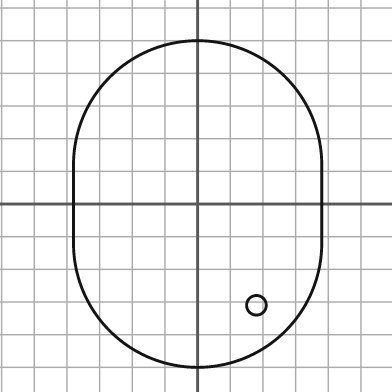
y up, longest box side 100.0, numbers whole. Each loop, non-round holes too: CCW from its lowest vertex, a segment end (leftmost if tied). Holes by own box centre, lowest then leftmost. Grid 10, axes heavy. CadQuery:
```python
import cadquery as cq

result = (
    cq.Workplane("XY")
    .moveTo(-38.0, -12.0)
    .threePointArc((0.0, -50.0), (38.0, -12.0))
    .lineTo(38.0, 12.0)
    .threePointArc((0.0, 50.0), (-38.0, 12.0))
    .close()
    .moveTo(18.0, -31.0)
    .circle(3.0)
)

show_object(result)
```